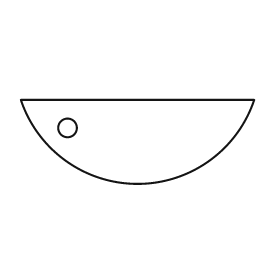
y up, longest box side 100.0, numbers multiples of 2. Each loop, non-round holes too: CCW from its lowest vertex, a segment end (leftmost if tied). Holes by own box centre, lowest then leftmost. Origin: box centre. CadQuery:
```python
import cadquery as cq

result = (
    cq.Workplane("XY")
    .moveTo(-50.0, 18.0)
    .threePointArc((0.0, -18.0), (50.0, 18.0))
    .close()
    .moveTo(-30.0, 6.0)
    .circle(4.0)
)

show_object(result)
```